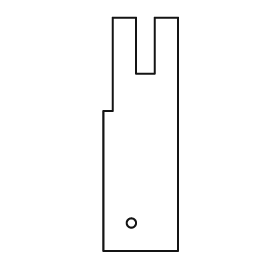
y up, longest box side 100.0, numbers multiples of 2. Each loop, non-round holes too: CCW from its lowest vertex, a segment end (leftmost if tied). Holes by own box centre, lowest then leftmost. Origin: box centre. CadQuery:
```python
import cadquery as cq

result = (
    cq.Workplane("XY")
    .moveTo(-16.0, -50.0)
    .lineTo(16.0, -50.0)
    .lineTo(16.0, 50.0)
    .lineTo(6.0, 50.0)
    .lineTo(6.0, 26.0)
    .lineTo(-2.0, 26.0)
    .lineTo(-2.0, 50.0)
    .lineTo(-12.0, 50.0)
    .lineTo(-12.0, 10.0)
    .lineTo(-16.0, 10.0)
    .close()
    .moveTo(-4.0, -38.0)
    .circle(2.0)
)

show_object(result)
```